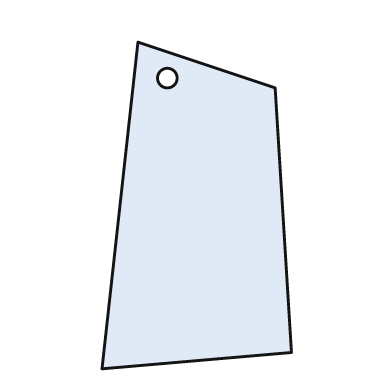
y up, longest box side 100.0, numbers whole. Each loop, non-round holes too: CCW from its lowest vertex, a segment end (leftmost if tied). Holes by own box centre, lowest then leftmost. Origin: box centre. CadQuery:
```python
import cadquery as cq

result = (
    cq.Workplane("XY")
    .moveTo(-29.0, -50.0)
    .lineTo(29.0, -45.0)
    .lineTo(24.0, 36.0)
    .lineTo(-18.0, 50.0)
    .close()
    .moveTo(-9.0, 39.0)
    .circle(3.0)
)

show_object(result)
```